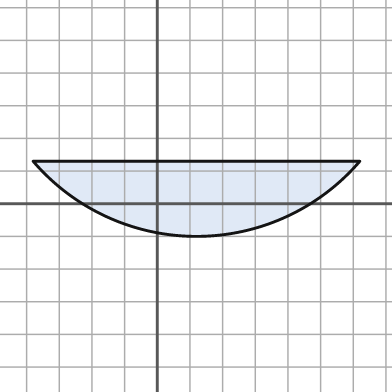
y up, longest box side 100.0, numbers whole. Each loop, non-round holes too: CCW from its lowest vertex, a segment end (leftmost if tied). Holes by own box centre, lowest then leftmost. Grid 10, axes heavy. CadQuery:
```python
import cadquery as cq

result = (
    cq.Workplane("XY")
    .moveTo(-38.0, 13.0)
    .threePointArc((12.0, -10.0), (62.0, 13.0))
    .close()
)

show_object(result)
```